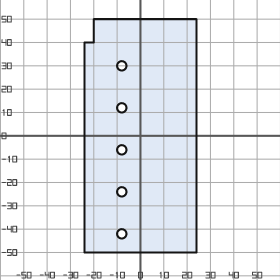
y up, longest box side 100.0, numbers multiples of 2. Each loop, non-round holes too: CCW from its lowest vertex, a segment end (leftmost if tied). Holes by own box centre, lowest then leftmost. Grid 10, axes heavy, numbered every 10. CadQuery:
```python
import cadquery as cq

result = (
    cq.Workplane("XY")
    .moveTo(-24.0, -50.0)
    .lineTo(24.0, -50.0)
    .lineTo(24.0, 50.0)
    .lineTo(-20.0, 50.0)
    .lineTo(-20.0, 40.0)
    .lineTo(-24.0, 40.0)
    .close()
    .moveTo(-8.0, -42.0)
    .circle(2.0)
    .moveTo(-8.0, -24.0)
    .circle(2.0)
    .moveTo(-8.0, -6.0)
    .circle(2.0)
    .moveTo(-8.0, 12.0)
    .circle(2.0)
    .moveTo(-8.0, 30.0)
    .circle(2.0)
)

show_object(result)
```